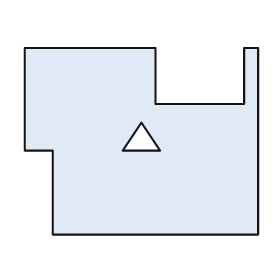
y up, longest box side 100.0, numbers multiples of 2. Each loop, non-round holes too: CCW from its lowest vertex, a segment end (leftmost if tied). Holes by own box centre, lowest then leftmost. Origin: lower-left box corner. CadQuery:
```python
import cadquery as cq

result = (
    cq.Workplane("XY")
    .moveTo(12.0, 0.0)
    .lineTo(100.0, 0.0)
    .lineTo(100.0, 80.0)
    .lineTo(94.0, 80.0)
    .lineTo(94.0, 56.0)
    .lineTo(56.0, 56.0)
    .lineTo(56.0, 80.0)
    .lineTo(0.0, 80.0)
    .lineTo(0.0, 36.0)
    .lineTo(12.0, 36.0)
    .close()
    .moveTo(42.0, 36.0)
    .lineTo(58.0, 36.0)
    .lineTo(50.0, 48.0)
    .close()
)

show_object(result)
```